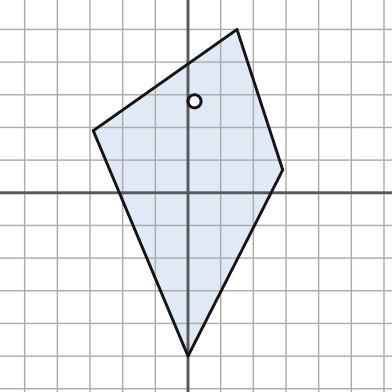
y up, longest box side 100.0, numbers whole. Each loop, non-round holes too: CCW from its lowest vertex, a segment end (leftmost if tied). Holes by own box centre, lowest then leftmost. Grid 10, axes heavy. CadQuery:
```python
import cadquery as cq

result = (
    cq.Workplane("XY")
    .moveTo(0.0, -50.0)
    .lineTo(29.0, 7.0)
    .lineTo(15.0, 50.0)
    .lineTo(-29.0, 19.0)
    .close()
    .moveTo(2.0, 28.0)
    .circle(2.0)
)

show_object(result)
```